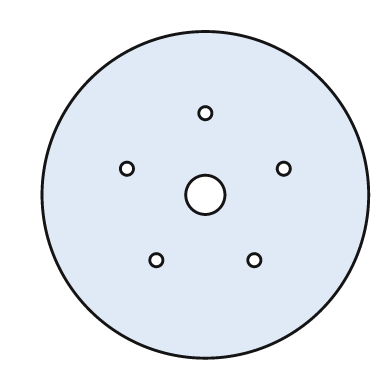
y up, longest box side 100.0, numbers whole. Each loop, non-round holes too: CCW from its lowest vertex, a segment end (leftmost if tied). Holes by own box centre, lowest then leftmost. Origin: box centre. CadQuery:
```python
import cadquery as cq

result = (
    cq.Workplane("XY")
    .moveTo(0.0, 0.0)
    .circle(50.0)
    .moveTo(-15.0, -20.0)
    .circle(2.0)
    .moveTo(15.0, -20.0)
    .circle(2.0)
    .moveTo(0.0, 0.0)
    .circle(6.0)
    .moveTo(-24.0, 8.0)
    .circle(2.0)
    .moveTo(24.0, 8.0)
    .circle(2.0)
    .moveTo(0.0, 25.0)
    .circle(2.0)
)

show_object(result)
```